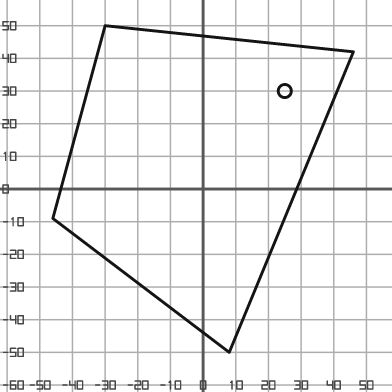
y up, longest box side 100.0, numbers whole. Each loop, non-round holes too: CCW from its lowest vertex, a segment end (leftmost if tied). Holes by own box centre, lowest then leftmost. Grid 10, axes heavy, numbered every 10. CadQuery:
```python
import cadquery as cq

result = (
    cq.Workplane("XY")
    .moveTo(8.0, -50.0)
    .lineTo(46.0, 42.0)
    .lineTo(-30.0, 50.0)
    .lineTo(-46.0, -9.0)
    .close()
    .moveTo(25.0, 30.0)
    .circle(2.0)
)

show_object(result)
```